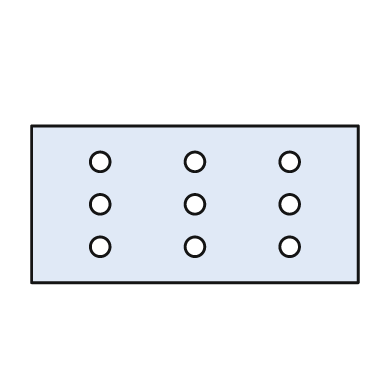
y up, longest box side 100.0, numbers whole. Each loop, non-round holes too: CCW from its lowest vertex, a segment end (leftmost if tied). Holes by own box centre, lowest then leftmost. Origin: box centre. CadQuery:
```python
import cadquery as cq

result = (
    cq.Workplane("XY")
    .moveTo(-50.0, -24.0)
    .lineTo(50.0, -24.0)
    .lineTo(50.0, 24.0)
    .lineTo(-50.0, 24.0)
    .close()
    .moveTo(-29.0, -13.0)
    .circle(3.0)
    .moveTo(0.0, -13.0)
    .circle(3.0)
    .moveTo(29.0, -13.0)
    .circle(3.0)
    .moveTo(-29.0, 0.0)
    .circle(3.0)
    .moveTo(0.0, 0.0)
    .circle(3.0)
    .moveTo(29.0, 0.0)
    .circle(3.0)
    .moveTo(-29.0, 13.0)
    .circle(3.0)
    .moveTo(0.0, 13.0)
    .circle(3.0)
    .moveTo(29.0, 13.0)
    .circle(3.0)
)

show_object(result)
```